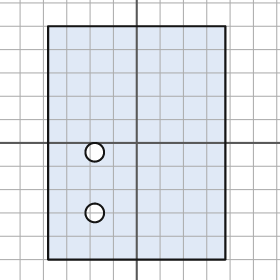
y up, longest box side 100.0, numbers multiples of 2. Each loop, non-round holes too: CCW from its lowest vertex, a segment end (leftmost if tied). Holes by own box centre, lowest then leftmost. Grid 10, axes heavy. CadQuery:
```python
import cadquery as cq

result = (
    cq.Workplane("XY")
    .moveTo(-38.0, -50.0)
    .lineTo(38.0, -50.0)
    .lineTo(38.0, 50.0)
    .lineTo(-38.0, 50.0)
    .close()
    .moveTo(-18.0, -30.0)
    .circle(4.0)
    .moveTo(-18.0, -4.0)
    .circle(4.0)
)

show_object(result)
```